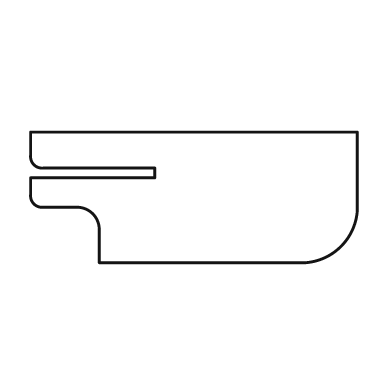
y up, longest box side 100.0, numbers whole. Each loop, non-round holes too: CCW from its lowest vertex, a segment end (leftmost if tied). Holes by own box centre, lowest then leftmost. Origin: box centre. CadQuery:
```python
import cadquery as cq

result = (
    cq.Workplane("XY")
    .moveTo(-29.0, -20.0)
    .lineTo(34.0, -20.0)
    .threePointArc((45.0, -15.0), (50.0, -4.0))
    .lineTo(50.0, 20.0)
    .lineTo(-50.0, 20.0)
    .lineTo(-50.0, 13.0)
    .threePointArc((-49.0, 10.0), (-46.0, 9.0))
    .lineTo(-12.0, 9.0)
    .lineTo(-12.0, 6.0)
    .lineTo(-50.0, 6.0)
    .lineTo(-50.0, 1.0)
    .threePointArc((-49.0, -2.0), (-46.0, -3.0))
    .lineTo(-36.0, -3.0)
    .threePointArc((-31.0, -5.0), (-29.0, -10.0))
    .close()
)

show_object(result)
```